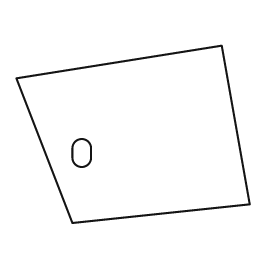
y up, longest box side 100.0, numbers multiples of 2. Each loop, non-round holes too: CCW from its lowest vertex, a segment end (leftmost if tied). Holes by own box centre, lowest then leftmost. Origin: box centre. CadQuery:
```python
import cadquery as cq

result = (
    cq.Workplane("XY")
    .moveTo(-26.0, -38.0)
    .lineTo(50.0, -30.0)
    .lineTo(38.0, 38.0)
    .lineTo(-50.0, 24.0)
    .close()
    .moveTo(-26.0, -10.0)
    .threePointArc((-22.0, -14.0), (-18.0, -10.0))
    .lineTo(-18.0, -6.0)
    .threePointArc((-22.0, -2.0), (-26.0, -6.0))
    .close()
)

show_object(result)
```